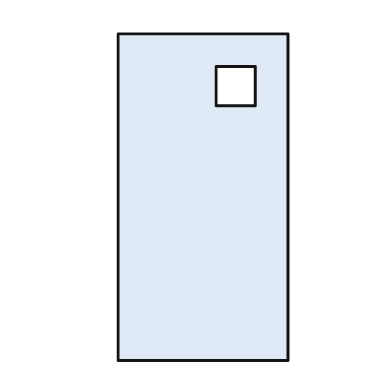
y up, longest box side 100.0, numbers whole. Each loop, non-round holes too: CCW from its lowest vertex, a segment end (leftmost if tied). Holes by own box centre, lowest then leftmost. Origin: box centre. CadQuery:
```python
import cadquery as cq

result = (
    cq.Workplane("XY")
    .moveTo(-26.0, -50.0)
    .lineTo(26.0, -50.0)
    .lineTo(26.0, 50.0)
    .lineTo(-26.0, 50.0)
    .close()
    .moveTo(4.0, 28.0)
    .lineTo(16.0, 28.0)
    .lineTo(16.0, 40.0)
    .lineTo(4.0, 40.0)
    .close()
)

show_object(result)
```